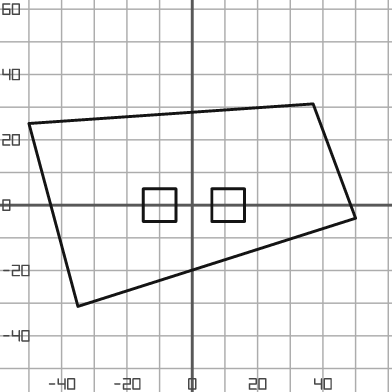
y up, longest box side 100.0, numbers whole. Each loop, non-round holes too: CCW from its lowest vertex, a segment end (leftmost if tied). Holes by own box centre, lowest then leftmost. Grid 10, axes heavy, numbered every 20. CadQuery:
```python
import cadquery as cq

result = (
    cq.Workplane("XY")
    .moveTo(-35.0, -31.0)
    .lineTo(50.0, -4.0)
    .lineTo(37.0, 31.0)
    .lineTo(-50.0, 25.0)
    .close()
    .moveTo(-15.0, -5.0)
    .lineTo(-5.0, -5.0)
    .lineTo(-5.0, 5.0)
    .lineTo(-15.0, 5.0)
    .close()
    .moveTo(6.0, -5.0)
    .lineTo(16.0, -5.0)
    .lineTo(16.0, 5.0)
    .lineTo(6.0, 5.0)
    .close()
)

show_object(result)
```